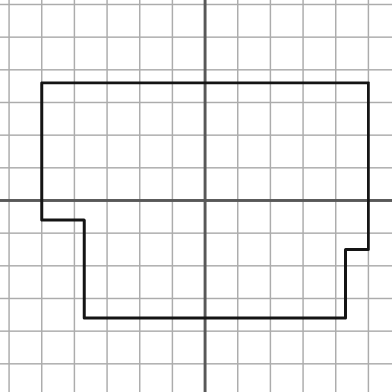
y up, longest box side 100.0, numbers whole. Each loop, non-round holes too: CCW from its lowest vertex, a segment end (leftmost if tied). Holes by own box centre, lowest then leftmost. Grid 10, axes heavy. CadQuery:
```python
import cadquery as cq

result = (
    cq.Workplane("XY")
    .moveTo(-37.0, -36.0)
    .lineTo(43.0, -36.0)
    .lineTo(43.0, -15.0)
    .lineTo(50.0, -15.0)
    .lineTo(50.0, 36.0)
    .lineTo(-50.0, 36.0)
    .lineTo(-50.0, -6.0)
    .lineTo(-37.0, -6.0)
    .close()
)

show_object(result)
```